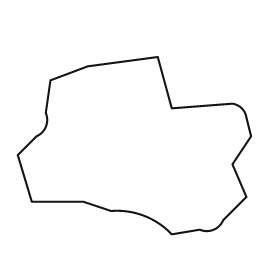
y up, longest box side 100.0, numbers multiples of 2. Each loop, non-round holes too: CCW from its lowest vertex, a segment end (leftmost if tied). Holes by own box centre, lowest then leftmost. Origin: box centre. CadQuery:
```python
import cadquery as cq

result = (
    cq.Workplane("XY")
    .moveTo(16.0, -38.0)
    .lineTo(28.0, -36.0)
    .threePointArc((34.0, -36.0), (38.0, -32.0))
    .lineTo(48.0, -22.0)
    .lineTo(42.0, -8.0)
    .lineTo(50.0, 4.0)
    .lineTo(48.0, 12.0)
    .threePointArc((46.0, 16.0), (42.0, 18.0))
    .lineTo(16.0, 16.0)
    .lineTo(10.0, 38.0)
    .lineTo(-20.0, 34.0)
    .lineTo(-36.0, 28.0)
    .lineTo(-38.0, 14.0)
    .threePointArc((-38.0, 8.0), (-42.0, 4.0))
    .lineTo(-50.0, -4.0)
    .lineTo(-44.0, -24.0)
    .lineTo(-22.0, -24.0)
    .lineTo(-10.0, -28.0)
    .threePointArc((4.0, -30.0), (16.0, -38.0))
    .close()
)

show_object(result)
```